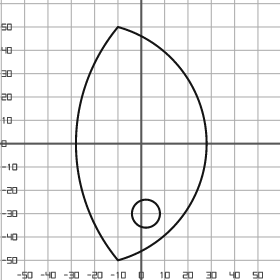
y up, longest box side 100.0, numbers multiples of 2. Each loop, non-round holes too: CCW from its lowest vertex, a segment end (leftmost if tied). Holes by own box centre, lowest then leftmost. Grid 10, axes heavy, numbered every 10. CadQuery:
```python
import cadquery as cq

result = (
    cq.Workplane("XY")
    .moveTo(-10.0, -50.0)
    .threePointArc((28.0, 0.0), (-10.0, 50.0))
    .threePointArc((-28.0, 0.0), (-10.0, -50.0))
    .close()
    .moveTo(2.0, -30.0)
    .circle(6.0)
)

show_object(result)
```